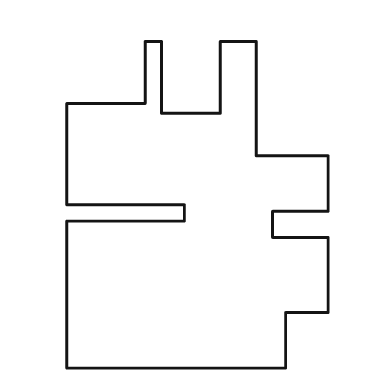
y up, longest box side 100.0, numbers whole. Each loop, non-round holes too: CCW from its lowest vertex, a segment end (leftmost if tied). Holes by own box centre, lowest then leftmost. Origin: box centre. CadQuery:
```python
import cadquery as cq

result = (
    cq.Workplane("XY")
    .moveTo(-40.0, -50.0)
    .lineTo(27.0, -50.0)
    .lineTo(27.0, -33.0)
    .lineTo(40.0, -33.0)
    .lineTo(40.0, -10.0)
    .lineTo(23.0, -10.0)
    .lineTo(23.0, -2.0)
    .lineTo(40.0, -2.0)
    .lineTo(40.0, 15.0)
    .lineTo(18.0, 15.0)
    .lineTo(18.0, 50.0)
    .lineTo(7.0, 50.0)
    .lineTo(7.0, 28.0)
    .lineTo(-11.0, 28.0)
    .lineTo(-11.0, 50.0)
    .lineTo(-16.0, 50.0)
    .lineTo(-16.0, 31.0)
    .lineTo(-40.0, 31.0)
    .lineTo(-40.0, 0.0)
    .lineTo(-4.0, 0.0)
    .lineTo(-4.0, -5.0)
    .lineTo(-40.0, -5.0)
    .close()
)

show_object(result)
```